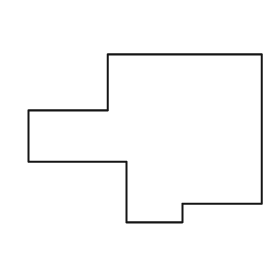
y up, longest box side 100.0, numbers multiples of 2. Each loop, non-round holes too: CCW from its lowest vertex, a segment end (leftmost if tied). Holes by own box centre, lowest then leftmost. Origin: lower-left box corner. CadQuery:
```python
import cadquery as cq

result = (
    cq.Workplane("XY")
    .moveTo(42.0, 0.0)
    .lineTo(66.0, 0.0)
    .lineTo(66.0, 8.0)
    .lineTo(100.0, 8.0)
    .lineTo(100.0, 72.0)
    .lineTo(34.0, 72.0)
    .lineTo(34.0, 48.0)
    .lineTo(0.0, 48.0)
    .lineTo(0.0, 26.0)
    .lineTo(42.0, 26.0)
    .close()
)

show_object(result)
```